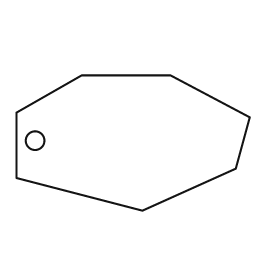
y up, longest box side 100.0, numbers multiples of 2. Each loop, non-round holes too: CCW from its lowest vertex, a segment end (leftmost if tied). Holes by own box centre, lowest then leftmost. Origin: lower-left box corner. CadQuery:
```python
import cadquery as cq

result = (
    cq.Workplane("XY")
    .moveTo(54.0, 0.0)
    .lineTo(94.0, 18.0)
    .lineTo(100.0, 40.0)
    .lineTo(66.0, 58.0)
    .lineTo(28.0, 58.0)
    .lineTo(0.0, 42.0)
    .lineTo(0.0, 14.0)
    .close()
    .moveTo(8.0, 30.0)
    .circle(4.0)
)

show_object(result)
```